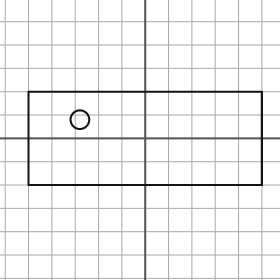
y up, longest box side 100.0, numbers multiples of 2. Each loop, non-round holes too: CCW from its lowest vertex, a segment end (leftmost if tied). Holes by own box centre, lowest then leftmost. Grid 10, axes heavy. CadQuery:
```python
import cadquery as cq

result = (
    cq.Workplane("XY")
    .moveTo(-50.0, -20.0)
    .lineTo(50.0, -20.0)
    .lineTo(50.0, 20.0)
    .lineTo(-50.0, 20.0)
    .close()
    .moveTo(-28.0, 8.0)
    .circle(4.0)
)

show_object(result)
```